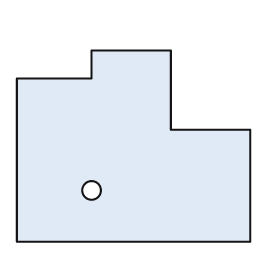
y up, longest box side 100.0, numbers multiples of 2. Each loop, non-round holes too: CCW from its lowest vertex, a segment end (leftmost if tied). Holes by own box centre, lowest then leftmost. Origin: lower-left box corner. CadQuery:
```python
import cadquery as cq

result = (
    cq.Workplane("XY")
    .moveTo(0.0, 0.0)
    .lineTo(100.0, 0.0)
    .lineTo(100.0, 48.0)
    .lineTo(66.0, 48.0)
    .lineTo(66.0, 82.0)
    .lineTo(32.0, 82.0)
    .lineTo(32.0, 70.0)
    .lineTo(0.0, 70.0)
    .close()
    .moveTo(32.0, 22.0)
    .circle(4.0)
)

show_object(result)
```